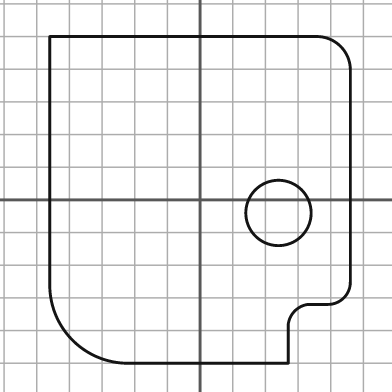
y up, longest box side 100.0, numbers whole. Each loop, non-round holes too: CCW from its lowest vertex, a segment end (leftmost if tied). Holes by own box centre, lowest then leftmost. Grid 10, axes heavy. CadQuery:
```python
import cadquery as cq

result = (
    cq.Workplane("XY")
    .moveTo(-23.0, -50.0)
    .lineTo(27.0, -50.0)
    .lineTo(27.0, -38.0)
    .threePointArc((29.0, -34.0), (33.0, -32.0))
    .lineTo(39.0, -32.0)
    .threePointArc((44.0, -30.0), (46.0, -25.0))
    .lineTo(46.0, 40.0)
    .threePointArc((43.0, 47.0), (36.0, 50.0))
    .lineTo(-46.0, 50.0)
    .lineTo(-46.0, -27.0)
    .threePointArc((-39.0, -43.0), (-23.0, -50.0))
    .close()
    .moveTo(24.0, -4.0)
    .circle(10.0)
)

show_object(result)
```